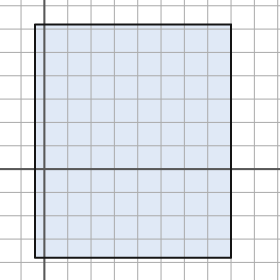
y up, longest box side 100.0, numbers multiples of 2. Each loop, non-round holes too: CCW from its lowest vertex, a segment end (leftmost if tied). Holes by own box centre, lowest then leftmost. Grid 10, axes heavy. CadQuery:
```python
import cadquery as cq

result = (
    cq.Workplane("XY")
    .moveTo(-4.0, -38.0)
    .lineTo(80.0, -38.0)
    .lineTo(80.0, 62.0)
    .lineTo(-4.0, 62.0)
    .close()
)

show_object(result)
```